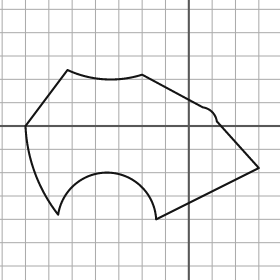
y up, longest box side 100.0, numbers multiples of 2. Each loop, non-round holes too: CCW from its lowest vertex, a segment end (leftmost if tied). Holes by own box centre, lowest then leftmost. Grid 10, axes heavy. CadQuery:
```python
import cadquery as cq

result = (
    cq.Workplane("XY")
    .moveTo(-14.0, -40.0)
    .lineTo(30.0, -18.0)
    .lineTo(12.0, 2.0)
    .threePointArc((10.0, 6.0), (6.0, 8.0))
    .lineTo(-20.0, 22.0)
    .threePointArc((-36.0, 20.0), (-52.0, 24.0))
    .lineTo(-70.0, 0.0)
    .threePointArc((-66.0, -20.0), (-56.0, -38.0))
    .threePointArc((-34.0, -20.0), (-14.0, -40.0))
    .close()
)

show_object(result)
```